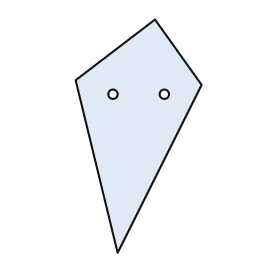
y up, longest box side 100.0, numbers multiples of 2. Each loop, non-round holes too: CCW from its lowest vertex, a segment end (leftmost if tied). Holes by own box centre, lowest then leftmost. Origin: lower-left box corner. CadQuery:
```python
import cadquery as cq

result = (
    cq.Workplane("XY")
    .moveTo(18.0, 0.0)
    .lineTo(54.0, 72.0)
    .lineTo(34.0, 100.0)
    .lineTo(0.0, 74.0)
    .close()
    .moveTo(16.0, 68.0)
    .circle(2.0)
    .moveTo(38.0, 68.0)
    .circle(2.0)
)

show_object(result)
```